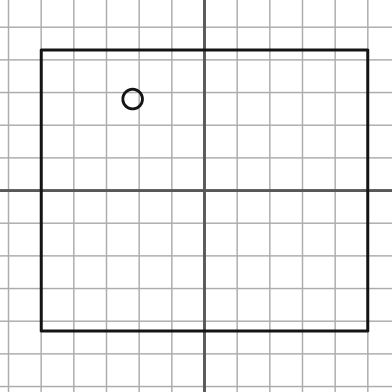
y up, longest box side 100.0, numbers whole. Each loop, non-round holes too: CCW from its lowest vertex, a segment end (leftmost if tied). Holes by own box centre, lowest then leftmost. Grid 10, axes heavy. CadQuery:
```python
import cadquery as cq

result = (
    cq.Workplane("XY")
    .moveTo(-50.0, -43.0)
    .lineTo(50.0, -43.0)
    .lineTo(50.0, 43.0)
    .lineTo(-50.0, 43.0)
    .close()
    .moveTo(-22.0, 28.0)
    .circle(3.0)
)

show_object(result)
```